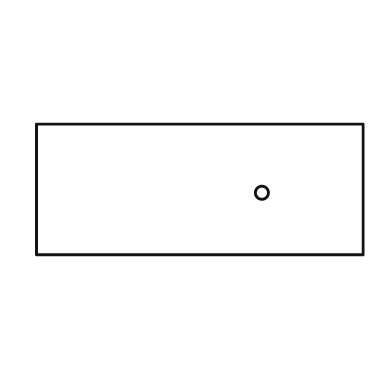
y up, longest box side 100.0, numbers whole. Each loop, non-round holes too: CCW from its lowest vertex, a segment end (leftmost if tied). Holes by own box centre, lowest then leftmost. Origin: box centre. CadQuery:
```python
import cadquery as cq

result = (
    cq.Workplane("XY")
    .moveTo(-50.0, -20.0)
    .lineTo(50.0, -20.0)
    .lineTo(50.0, 20.0)
    .lineTo(-50.0, 20.0)
    .close()
    .moveTo(19.0, -1.0)
    .circle(2.0)
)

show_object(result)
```